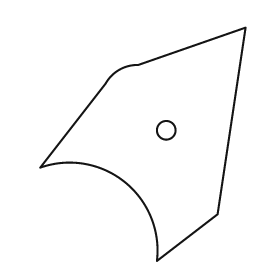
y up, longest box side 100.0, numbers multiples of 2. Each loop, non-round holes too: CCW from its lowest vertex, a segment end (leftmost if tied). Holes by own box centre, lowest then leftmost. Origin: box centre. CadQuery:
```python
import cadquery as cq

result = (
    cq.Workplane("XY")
    .moveTo(6.0, -50.0)
    .lineTo(32.0, -30.0)
    .lineTo(44.0, 50.0)
    .lineTo(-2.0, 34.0)
    .threePointArc((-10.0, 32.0), (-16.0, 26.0))
    .lineTo(-44.0, -10.0)
    .threePointArc((-8.0, -16.0), (6.0, -50.0))
    .close()
    .moveTo(10.0, 6.0)
    .circle(4.0)
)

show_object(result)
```